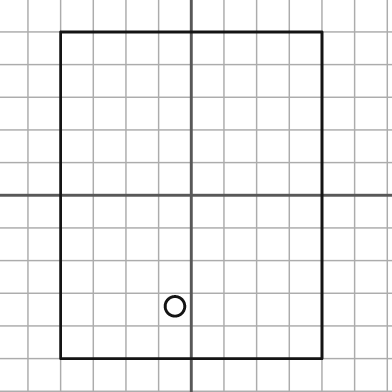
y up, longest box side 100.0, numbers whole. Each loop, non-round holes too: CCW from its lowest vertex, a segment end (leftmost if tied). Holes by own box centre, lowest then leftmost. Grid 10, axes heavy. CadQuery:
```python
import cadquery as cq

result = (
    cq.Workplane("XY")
    .moveTo(-40.0, -50.0)
    .lineTo(40.0, -50.0)
    .lineTo(40.0, 50.0)
    .lineTo(-40.0, 50.0)
    .close()
    .moveTo(-5.0, -34.0)
    .circle(3.0)
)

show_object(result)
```